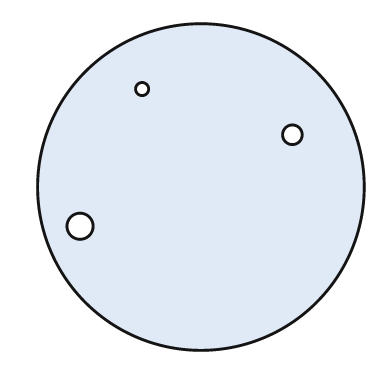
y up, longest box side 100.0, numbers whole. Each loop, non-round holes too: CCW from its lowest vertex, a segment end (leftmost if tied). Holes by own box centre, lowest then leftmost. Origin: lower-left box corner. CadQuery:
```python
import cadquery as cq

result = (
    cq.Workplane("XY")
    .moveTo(50.0, 50.0)
    .circle(50.0)
    .moveTo(13.0, 38.0)
    .circle(4.0)
    .moveTo(78.0, 66.0)
    .circle(3.0)
    .moveTo(32.0, 80.0)
    .circle(2.0)
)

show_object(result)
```